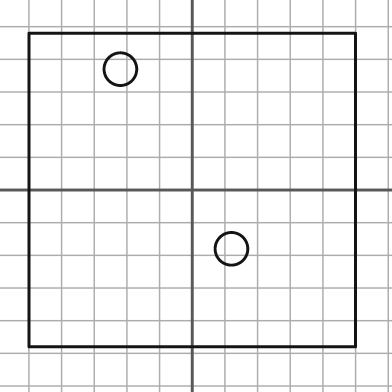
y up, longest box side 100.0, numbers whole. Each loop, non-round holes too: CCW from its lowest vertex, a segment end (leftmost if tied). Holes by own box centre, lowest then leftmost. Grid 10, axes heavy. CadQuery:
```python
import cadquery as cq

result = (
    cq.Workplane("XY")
    .moveTo(-50.0, -48.0)
    .lineTo(50.0, -48.0)
    .lineTo(50.0, 48.0)
    .lineTo(-50.0, 48.0)
    .close()
    .moveTo(12.0, -18.0)
    .circle(5.0)
    .moveTo(-22.0, 37.0)
    .circle(5.0)
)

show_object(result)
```